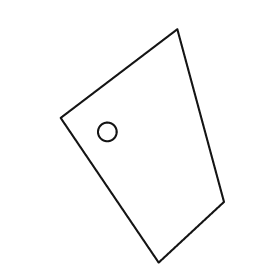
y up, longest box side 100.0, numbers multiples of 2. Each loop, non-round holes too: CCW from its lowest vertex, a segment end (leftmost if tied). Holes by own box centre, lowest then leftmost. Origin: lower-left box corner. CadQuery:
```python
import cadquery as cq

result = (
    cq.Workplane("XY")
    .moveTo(42.0, 0.0)
    .lineTo(70.0, 26.0)
    .lineTo(50.0, 100.0)
    .lineTo(0.0, 62.0)
    .close()
    .moveTo(20.0, 56.0)
    .circle(4.0)
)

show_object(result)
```